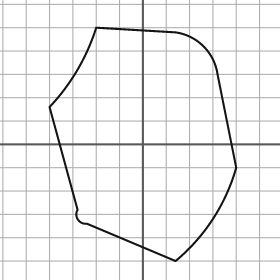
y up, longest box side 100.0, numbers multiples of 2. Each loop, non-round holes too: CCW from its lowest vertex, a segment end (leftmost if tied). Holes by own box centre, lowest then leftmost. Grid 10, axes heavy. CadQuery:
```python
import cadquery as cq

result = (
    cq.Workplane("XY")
    .moveTo(14.0, -50.0)
    .threePointArc((30.0, -32.0), (40.0, -10.0))
    .lineTo(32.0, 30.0)
    .threePointArc((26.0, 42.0), (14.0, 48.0))
    .lineTo(-20.0, 50.0)
    .threePointArc((-28.0, 32.0), (-40.0, 16.0))
    .lineTo(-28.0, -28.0)
    .threePointArc((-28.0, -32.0), (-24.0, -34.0))
    .close()
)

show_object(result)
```